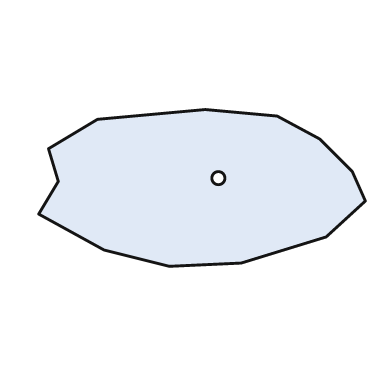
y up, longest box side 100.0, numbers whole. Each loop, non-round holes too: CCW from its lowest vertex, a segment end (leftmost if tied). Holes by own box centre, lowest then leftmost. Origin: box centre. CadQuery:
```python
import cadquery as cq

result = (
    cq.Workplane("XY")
    .moveTo(-10.0, -24.0)
    .lineTo(12.0, -23.0)
    .lineTo(38.0, -15.0)
    .lineTo(50.0, -4.0)
    .lineTo(46.0, 5.0)
    .lineTo(36.0, 15.0)
    .lineTo(23.0, 22.0)
    .lineTo(1.0, 24.0)
    .lineTo(-32.0, 21.0)
    .lineTo(-47.0, 12.0)
    .lineTo(-44.0, 2.0)
    .lineTo(-50.0, -8.0)
    .lineTo(-30.0, -19.0)
    .close()
    .moveTo(5.0, 3.0)
    .circle(2.0)
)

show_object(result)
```